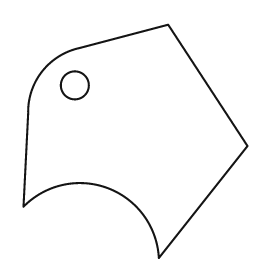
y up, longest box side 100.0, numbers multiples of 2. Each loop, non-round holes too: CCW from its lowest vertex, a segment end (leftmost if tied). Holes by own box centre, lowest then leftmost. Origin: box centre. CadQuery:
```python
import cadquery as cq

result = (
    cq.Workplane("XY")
    .moveTo(10.0, -50.0)
    .lineTo(48.0, -2.0)
    .lineTo(14.0, 50.0)
    .lineTo(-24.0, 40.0)
    .threePointArc((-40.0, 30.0), (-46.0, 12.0))
    .lineTo(-48.0, -28.0)
    .threePointArc((-12.0, -20.0), (10.0, -50.0))
    .close()
    .moveTo(-26.0, 24.0)
    .circle(6.0)
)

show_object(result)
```